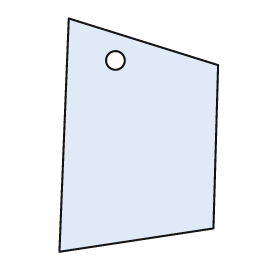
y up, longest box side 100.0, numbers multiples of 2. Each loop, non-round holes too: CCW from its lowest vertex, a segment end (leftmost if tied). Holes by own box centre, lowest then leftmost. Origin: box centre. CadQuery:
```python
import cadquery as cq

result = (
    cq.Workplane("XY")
    .moveTo(-34.0, -50.0)
    .lineTo(32.0, -40.0)
    .lineTo(34.0, 30.0)
    .lineTo(-30.0, 50.0)
    .close()
    .moveTo(-10.0, 32.0)
    .circle(4.0)
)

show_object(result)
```